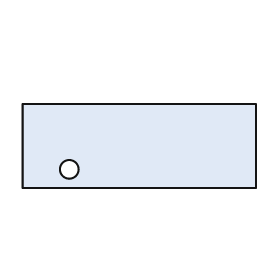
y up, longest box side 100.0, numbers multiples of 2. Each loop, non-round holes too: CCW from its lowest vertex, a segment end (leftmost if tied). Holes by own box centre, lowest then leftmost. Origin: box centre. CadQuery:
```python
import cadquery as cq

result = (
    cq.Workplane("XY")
    .moveTo(-50.0, -18.0)
    .lineTo(50.0, -18.0)
    .lineTo(50.0, 18.0)
    .lineTo(-50.0, 18.0)
    .close()
    .moveTo(-30.0, -10.0)
    .circle(4.0)
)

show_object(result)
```